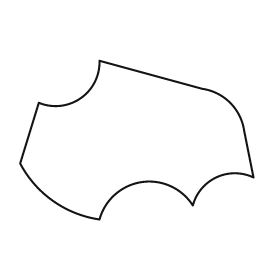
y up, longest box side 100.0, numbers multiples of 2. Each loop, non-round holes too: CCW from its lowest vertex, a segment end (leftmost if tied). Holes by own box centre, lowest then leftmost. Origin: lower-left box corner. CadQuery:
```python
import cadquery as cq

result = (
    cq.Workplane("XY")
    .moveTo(34.0, 0.0)
    .threePointArc((52.0, 16.0), (74.0, 6.0))
    .threePointArc((84.0, 18.0), (100.0, 18.0))
    .lineTo(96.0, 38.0)
    .threePointArc((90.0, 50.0), (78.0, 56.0))
    .lineTo(34.0, 68.0)
    .threePointArc((26.0, 52.0), (8.0, 50.0))
    .lineTo(0.0, 24.0)
    .threePointArc((14.0, 8.0), (34.0, 0.0))
    .close()
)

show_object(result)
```